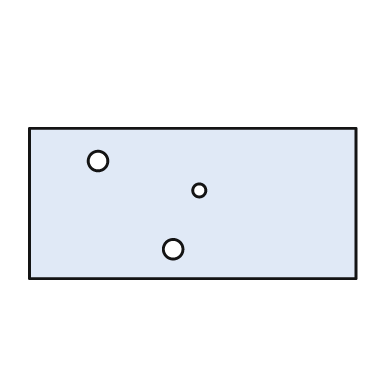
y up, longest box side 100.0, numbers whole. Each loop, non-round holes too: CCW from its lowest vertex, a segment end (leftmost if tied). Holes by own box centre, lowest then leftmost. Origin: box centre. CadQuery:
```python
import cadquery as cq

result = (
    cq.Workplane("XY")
    .moveTo(-50.0, -23.0)
    .lineTo(50.0, -23.0)
    .lineTo(50.0, 23.0)
    .lineTo(-50.0, 23.0)
    .close()
    .moveTo(-6.0, -14.0)
    .circle(3.0)
    .moveTo(2.0, 4.0)
    .circle(2.0)
    .moveTo(-29.0, 13.0)
    .circle(3.0)
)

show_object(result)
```